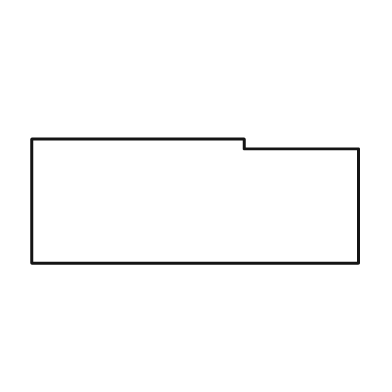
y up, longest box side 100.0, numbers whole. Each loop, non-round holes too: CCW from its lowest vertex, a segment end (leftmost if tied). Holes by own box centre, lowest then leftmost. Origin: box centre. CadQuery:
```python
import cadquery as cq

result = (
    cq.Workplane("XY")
    .moveTo(-50.0, -19.0)
    .lineTo(50.0, -19.0)
    .lineTo(50.0, 16.0)
    .lineTo(15.0, 16.0)
    .lineTo(15.0, 19.0)
    .lineTo(-50.0, 19.0)
    .close()
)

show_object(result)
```